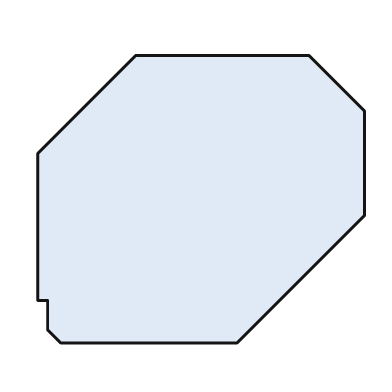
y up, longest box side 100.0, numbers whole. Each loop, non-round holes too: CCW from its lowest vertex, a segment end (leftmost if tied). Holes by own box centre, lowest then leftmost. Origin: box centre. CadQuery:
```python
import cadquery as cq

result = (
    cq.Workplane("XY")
    .moveTo(-43.0, -44.0)
    .lineTo(11.0, -44.0)
    .lineTo(50.0, -5.0)
    .lineTo(50.0, 27.0)
    .lineTo(33.0, 44.0)
    .lineTo(-20.0, 44.0)
    .lineTo(-50.0, 14.0)
    .lineTo(-50.0, -31.0)
    .lineTo(-47.0, -31.0)
    .lineTo(-47.0, -40.0)
    .close()
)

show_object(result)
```